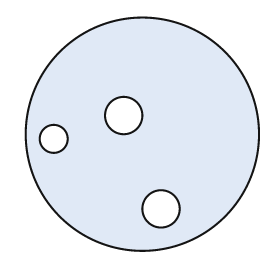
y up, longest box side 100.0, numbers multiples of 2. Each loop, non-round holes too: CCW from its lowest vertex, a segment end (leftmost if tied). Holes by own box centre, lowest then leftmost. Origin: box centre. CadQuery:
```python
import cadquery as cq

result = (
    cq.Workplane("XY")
    .moveTo(0.0, 0.0)
    .circle(50.0)
    .moveTo(8.0, -32.0)
    .circle(8.0)
    .moveTo(-38.0, -2.0)
    .circle(6.0)
    .moveTo(-8.0, 8.0)
    .circle(8.0)
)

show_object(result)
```